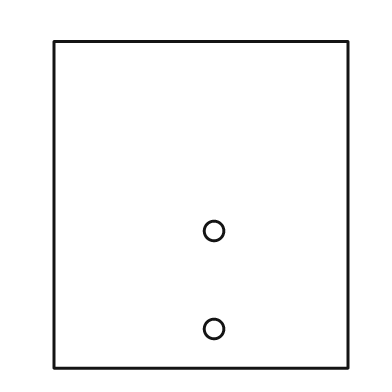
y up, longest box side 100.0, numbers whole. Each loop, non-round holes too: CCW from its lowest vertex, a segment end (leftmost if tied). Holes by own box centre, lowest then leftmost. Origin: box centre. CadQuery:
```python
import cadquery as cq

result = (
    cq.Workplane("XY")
    .moveTo(-45.0, -50.0)
    .lineTo(45.0, -50.0)
    .lineTo(45.0, 50.0)
    .lineTo(-45.0, 50.0)
    .close()
    .moveTo(4.0, -38.0)
    .circle(3.0)
    .moveTo(4.0, -8.0)
    .circle(3.0)
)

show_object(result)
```